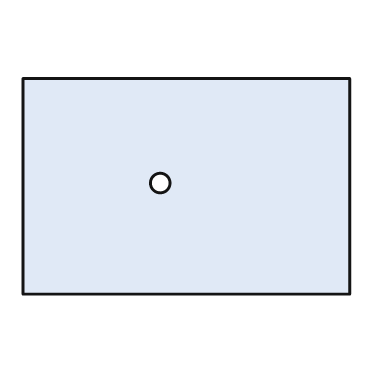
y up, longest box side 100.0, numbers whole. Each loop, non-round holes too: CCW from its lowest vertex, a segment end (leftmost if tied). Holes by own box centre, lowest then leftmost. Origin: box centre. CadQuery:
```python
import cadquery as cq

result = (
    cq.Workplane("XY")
    .moveTo(-50.0, -33.0)
    .lineTo(50.0, -33.0)
    .lineTo(50.0, 33.0)
    .lineTo(-50.0, 33.0)
    .close()
    .moveTo(-8.0, 1.0)
    .circle(3.0)
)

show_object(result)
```